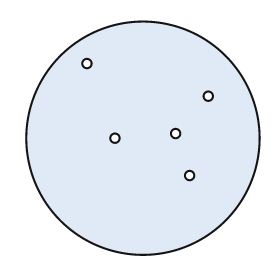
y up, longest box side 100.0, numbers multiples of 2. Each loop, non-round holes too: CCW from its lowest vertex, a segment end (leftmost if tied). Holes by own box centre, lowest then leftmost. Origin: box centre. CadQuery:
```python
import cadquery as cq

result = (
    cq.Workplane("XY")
    .moveTo(0.0, 0.0)
    .circle(50.0)
    .moveTo(20.0, -16.0)
    .circle(2.0)
    .moveTo(-12.0, 0.0)
    .circle(2.0)
    .moveTo(14.0, 2.0)
    .circle(2.0)
    .moveTo(28.0, 18.0)
    .circle(2.0)
    .moveTo(-24.0, 32.0)
    .circle(2.0)
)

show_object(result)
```